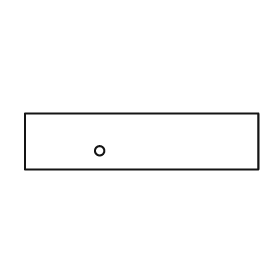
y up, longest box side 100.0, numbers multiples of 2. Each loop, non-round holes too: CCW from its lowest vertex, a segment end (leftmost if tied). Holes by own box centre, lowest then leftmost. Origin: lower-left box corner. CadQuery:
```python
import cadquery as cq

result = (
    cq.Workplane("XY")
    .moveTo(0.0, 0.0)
    .lineTo(100.0, 0.0)
    .lineTo(100.0, 24.0)
    .lineTo(0.0, 24.0)
    .close()
    .moveTo(32.0, 8.0)
    .circle(2.0)
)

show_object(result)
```